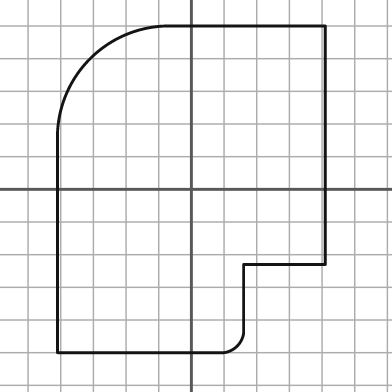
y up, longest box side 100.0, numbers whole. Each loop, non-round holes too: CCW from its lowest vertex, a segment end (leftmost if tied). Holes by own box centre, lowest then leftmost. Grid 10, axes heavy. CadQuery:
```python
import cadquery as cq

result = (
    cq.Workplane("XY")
    .moveTo(-41.0, -50.0)
    .lineTo(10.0, -50.0)
    .threePointArc((14.0, -48.0), (16.0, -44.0))
    .lineTo(16.0, -23.0)
    .lineTo(41.0, -23.0)
    .lineTo(41.0, 50.0)
    .lineTo(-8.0, 50.0)
    .threePointArc((-31.0, 40.0), (-41.0, 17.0))
    .close()
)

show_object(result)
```